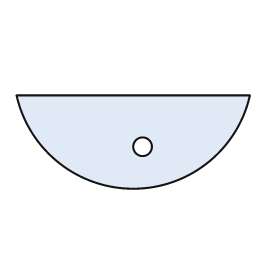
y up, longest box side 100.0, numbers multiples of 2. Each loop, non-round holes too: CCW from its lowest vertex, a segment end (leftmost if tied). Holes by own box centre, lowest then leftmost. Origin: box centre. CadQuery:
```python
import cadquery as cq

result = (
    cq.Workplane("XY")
    .moveTo(-50.0, 20.0)
    .threePointArc((0.0, -20.0), (50.0, 20.0))
    .close()
    .moveTo(4.0, -2.0)
    .circle(4.0)
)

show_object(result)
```